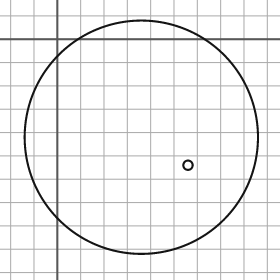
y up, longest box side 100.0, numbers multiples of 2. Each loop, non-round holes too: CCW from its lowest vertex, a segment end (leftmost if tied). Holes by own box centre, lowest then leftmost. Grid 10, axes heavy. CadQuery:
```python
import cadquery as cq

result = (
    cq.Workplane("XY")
    .moveTo(36.0, -42.0)
    .circle(50.0)
    .moveTo(56.0, -54.0)
    .circle(2.0)
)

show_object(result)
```